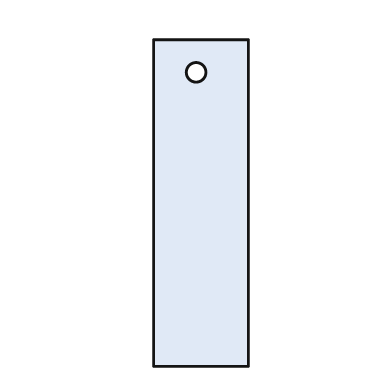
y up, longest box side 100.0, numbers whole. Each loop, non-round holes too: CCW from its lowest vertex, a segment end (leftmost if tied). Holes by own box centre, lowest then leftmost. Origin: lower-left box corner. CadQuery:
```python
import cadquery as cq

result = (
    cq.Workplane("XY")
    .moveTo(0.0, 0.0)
    .lineTo(29.0, 0.0)
    .lineTo(29.0, 100.0)
    .lineTo(0.0, 100.0)
    .close()
    .moveTo(13.0, 90.0)
    .circle(3.0)
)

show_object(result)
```